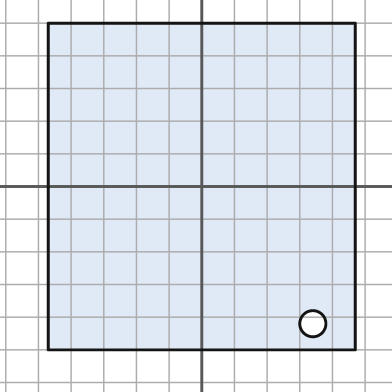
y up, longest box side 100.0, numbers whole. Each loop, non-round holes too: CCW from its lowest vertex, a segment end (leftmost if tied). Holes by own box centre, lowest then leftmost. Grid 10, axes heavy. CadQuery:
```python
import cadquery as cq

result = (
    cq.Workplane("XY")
    .moveTo(-47.0, -50.0)
    .lineTo(47.0, -50.0)
    .lineTo(47.0, 50.0)
    .lineTo(-47.0, 50.0)
    .close()
    .moveTo(34.0, -42.0)
    .circle(4.0)
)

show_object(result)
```